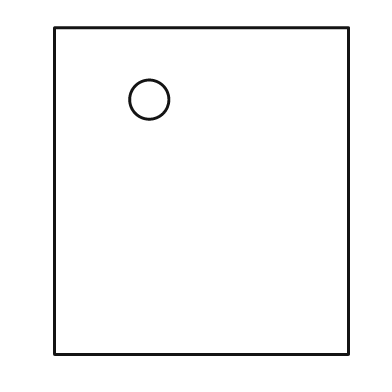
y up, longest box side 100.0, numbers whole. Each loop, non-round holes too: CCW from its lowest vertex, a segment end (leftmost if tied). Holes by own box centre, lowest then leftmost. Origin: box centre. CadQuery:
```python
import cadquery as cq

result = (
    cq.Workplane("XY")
    .moveTo(-45.0, -50.0)
    .lineTo(45.0, -50.0)
    .lineTo(45.0, 50.0)
    .lineTo(-45.0, 50.0)
    .close()
    .moveTo(-16.0, 28.0)
    .circle(6.0)
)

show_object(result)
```